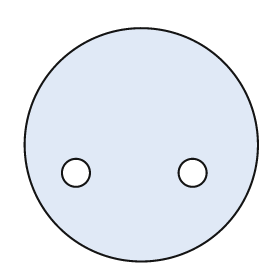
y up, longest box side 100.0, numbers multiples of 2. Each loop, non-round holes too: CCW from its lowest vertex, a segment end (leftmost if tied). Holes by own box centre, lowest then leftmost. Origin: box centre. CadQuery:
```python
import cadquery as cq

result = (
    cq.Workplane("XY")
    .moveTo(0.0, 0.0)
    .circle(50.0)
    .moveTo(-28.0, -12.0)
    .circle(6.0)
    .moveTo(22.0, -12.0)
    .circle(6.0)
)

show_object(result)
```